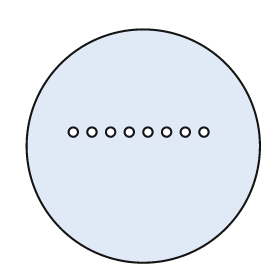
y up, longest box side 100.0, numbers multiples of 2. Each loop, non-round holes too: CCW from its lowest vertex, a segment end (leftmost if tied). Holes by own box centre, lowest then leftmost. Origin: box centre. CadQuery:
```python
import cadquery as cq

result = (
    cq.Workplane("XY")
    .moveTo(0.0, 0.0)
    .circle(50.0)
    .moveTo(-30.0, 6.0)
    .circle(2.0)
    .moveTo(-22.0, 6.0)
    .circle(2.0)
    .moveTo(-14.0, 6.0)
    .circle(2.0)
    .moveTo(-6.0, 6.0)
    .circle(2.0)
    .moveTo(2.0, 6.0)
    .circle(2.0)
    .moveTo(10.0, 6.0)
    .circle(2.0)
    .moveTo(18.0, 6.0)
    .circle(2.0)
    .moveTo(26.0, 6.0)
    .circle(2.0)
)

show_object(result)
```